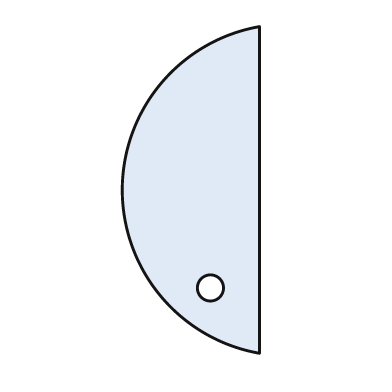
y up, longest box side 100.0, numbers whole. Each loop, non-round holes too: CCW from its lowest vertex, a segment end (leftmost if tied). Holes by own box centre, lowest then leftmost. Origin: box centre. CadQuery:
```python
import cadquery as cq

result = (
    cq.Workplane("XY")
    .moveTo(21.0, -50.0)
    .lineTo(21.0, 50.0)
    .threePointArc((-21.0, 0.0), (21.0, -50.0))
    .close()
    .moveTo(6.0, -30.0)
    .circle(4.0)
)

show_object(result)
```